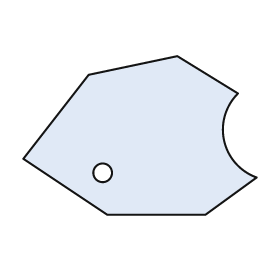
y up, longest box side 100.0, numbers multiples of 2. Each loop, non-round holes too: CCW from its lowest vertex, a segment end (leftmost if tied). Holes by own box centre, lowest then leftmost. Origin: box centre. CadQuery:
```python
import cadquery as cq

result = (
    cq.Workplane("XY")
    .moveTo(-14.0, -34.0)
    .lineTo(28.0, -34.0)
    .lineTo(50.0, -18.0)
    .threePointArc((36.0, -2.0), (42.0, 18.0))
    .lineTo(16.0, 34.0)
    .lineTo(-22.0, 26.0)
    .lineTo(-50.0, -10.0)
    .close()
    .moveTo(-16.0, -16.0)
    .circle(4.0)
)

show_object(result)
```